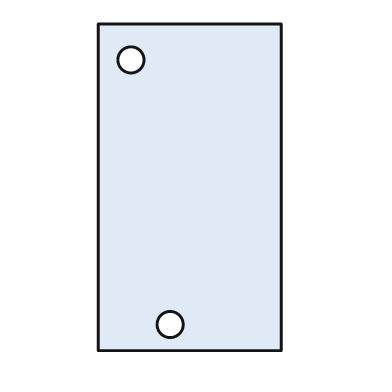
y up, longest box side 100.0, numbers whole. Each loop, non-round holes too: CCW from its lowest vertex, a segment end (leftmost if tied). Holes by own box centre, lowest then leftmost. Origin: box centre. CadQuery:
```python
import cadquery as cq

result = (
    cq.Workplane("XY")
    .moveTo(-28.0, -50.0)
    .lineTo(28.0, -50.0)
    .lineTo(28.0, 50.0)
    .lineTo(-28.0, 50.0)
    .close()
    .moveTo(-6.0, -42.0)
    .circle(4.0)
    .moveTo(-18.0, 39.0)
    .circle(4.0)
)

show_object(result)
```